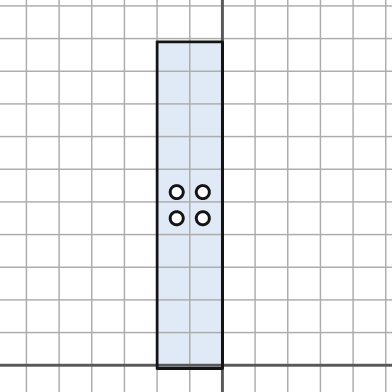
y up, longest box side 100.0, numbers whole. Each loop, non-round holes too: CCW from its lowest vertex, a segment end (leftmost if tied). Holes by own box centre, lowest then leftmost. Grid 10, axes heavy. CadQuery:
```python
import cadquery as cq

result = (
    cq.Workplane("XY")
    .moveTo(-20.0, -1.0)
    .lineTo(0.0, -1.0)
    .lineTo(0.0, 99.0)
    .lineTo(-20.0, 99.0)
    .close()
    .moveTo(-14.0, 45.0)
    .circle(2.0)
    .moveTo(-6.0, 45.0)
    .circle(2.0)
    .moveTo(-14.0, 53.0)
    .circle(2.0)
    .moveTo(-6.0, 53.0)
    .circle(2.0)
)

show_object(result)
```